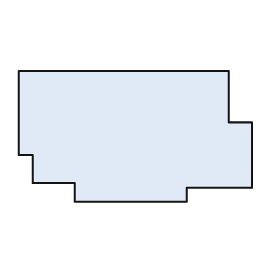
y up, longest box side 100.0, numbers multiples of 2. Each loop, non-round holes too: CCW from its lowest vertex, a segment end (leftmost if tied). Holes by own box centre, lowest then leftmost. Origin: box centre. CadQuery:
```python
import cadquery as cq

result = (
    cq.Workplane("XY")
    .moveTo(-26.0, -28.0)
    .lineTo(22.0, -28.0)
    .lineTo(22.0, -22.0)
    .lineTo(50.0, -22.0)
    .lineTo(50.0, 6.0)
    .lineTo(40.0, 6.0)
    .lineTo(40.0, 28.0)
    .lineTo(-50.0, 28.0)
    .lineTo(-50.0, -8.0)
    .lineTo(-44.0, -8.0)
    .lineTo(-44.0, -20.0)
    .lineTo(-26.0, -20.0)
    .close()
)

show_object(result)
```